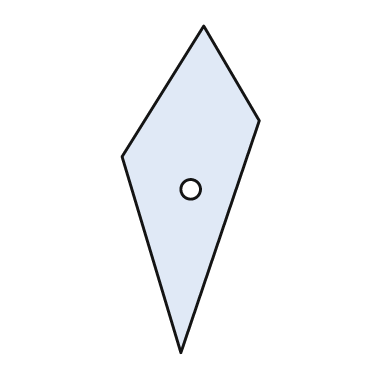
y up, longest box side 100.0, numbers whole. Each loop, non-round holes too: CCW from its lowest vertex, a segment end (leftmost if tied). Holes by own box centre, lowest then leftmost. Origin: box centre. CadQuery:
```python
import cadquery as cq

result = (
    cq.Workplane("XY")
    .moveTo(-3.0, -50.0)
    .lineTo(21.0, 21.0)
    .lineTo(4.0, 50.0)
    .lineTo(-21.0, 10.0)
    .close()
    .moveTo(0.0, 0.0)
    .circle(3.0)
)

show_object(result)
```